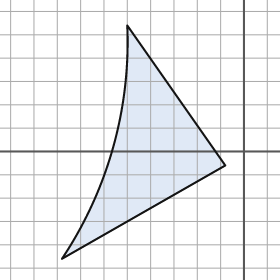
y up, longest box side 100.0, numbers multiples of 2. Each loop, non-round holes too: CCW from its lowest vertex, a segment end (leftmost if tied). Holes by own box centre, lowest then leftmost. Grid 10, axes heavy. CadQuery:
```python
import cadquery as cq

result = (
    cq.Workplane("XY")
    .moveTo(-78.0, -46.0)
    .lineTo(-8.0, -6.0)
    .lineTo(-50.0, 54.0)
    .threePointArc((-56.0, 2.0), (-78.0, -46.0))
    .close()
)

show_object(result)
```